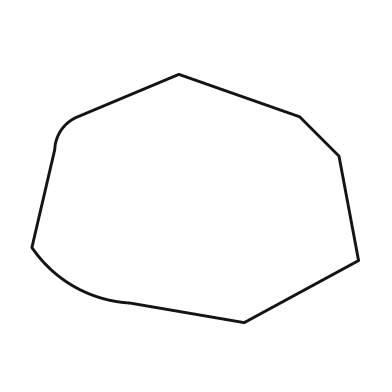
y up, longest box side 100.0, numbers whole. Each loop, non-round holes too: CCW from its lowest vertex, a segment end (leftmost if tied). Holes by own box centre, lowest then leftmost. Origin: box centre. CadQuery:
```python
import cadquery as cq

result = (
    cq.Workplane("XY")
    .moveTo(15.0, -38.0)
    .lineTo(50.0, -19.0)
    .lineTo(44.0, 13.0)
    .lineTo(32.0, 25.0)
    .lineTo(-5.0, 38.0)
    .lineTo(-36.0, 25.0)
    .threePointArc((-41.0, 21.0), (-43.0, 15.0))
    .lineTo(-50.0, -15.0)
    .threePointArc((-37.0, -27.0), (-20.0, -32.0))
    .close()
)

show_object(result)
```